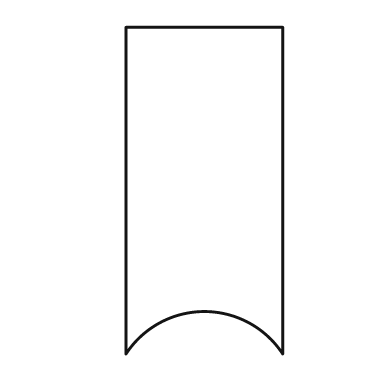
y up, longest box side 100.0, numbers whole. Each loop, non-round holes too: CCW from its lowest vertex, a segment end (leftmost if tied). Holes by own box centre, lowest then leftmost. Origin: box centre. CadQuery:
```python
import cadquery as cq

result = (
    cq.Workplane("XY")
    .moveTo(-24.0, -50.0)
    .threePointArc((0.0, -37.0), (24.0, -50.0))
    .lineTo(24.0, 50.0)
    .lineTo(-24.0, 50.0)
    .close()
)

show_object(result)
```